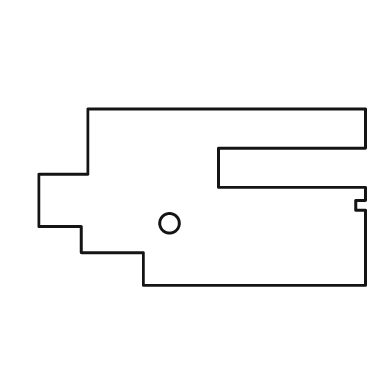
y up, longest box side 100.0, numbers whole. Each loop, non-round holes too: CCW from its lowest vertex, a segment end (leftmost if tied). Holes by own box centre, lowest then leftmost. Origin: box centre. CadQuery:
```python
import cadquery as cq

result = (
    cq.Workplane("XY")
    .moveTo(-18.0, -27.0)
    .lineTo(50.0, -27.0)
    .lineTo(50.0, -4.0)
    .lineTo(47.0, -4.0)
    .lineTo(47.0, -1.0)
    .lineTo(50.0, -1.0)
    .lineTo(50.0, 3.0)
    .lineTo(5.0, 3.0)
    .lineTo(5.0, 15.0)
    .lineTo(50.0, 15.0)
    .lineTo(50.0, 27.0)
    .lineTo(-35.0, 27.0)
    .lineTo(-35.0, 7.0)
    .lineTo(-50.0, 7.0)
    .lineTo(-50.0, -9.0)
    .lineTo(-37.0, -9.0)
    .lineTo(-37.0, -17.0)
    .lineTo(-18.0, -17.0)
    .close()
    .moveTo(-10.0, -8.0)
    .circle(3.0)
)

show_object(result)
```